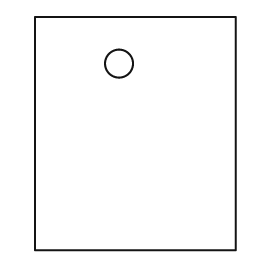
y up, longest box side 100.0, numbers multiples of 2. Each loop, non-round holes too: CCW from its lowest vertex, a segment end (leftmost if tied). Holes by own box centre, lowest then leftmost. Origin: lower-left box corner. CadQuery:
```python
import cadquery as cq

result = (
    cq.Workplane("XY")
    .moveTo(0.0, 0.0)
    .lineTo(86.0, 0.0)
    .lineTo(86.0, 100.0)
    .lineTo(0.0, 100.0)
    .close()
    .moveTo(36.0, 80.0)
    .circle(6.0)
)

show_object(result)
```